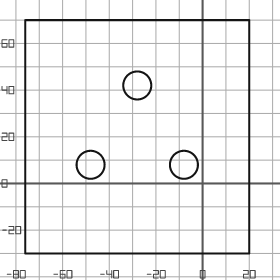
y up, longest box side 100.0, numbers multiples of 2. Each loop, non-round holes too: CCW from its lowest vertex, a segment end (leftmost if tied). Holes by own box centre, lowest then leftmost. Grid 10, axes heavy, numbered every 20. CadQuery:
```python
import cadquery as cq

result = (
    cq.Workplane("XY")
    .moveTo(-76.0, -30.0)
    .lineTo(20.0, -30.0)
    .lineTo(20.0, 70.0)
    .lineTo(-76.0, 70.0)
    .close()
    .moveTo(-48.0, 8.0)
    .circle(6.0)
    .moveTo(-8.0, 8.0)
    .circle(6.0)
    .moveTo(-28.0, 42.0)
    .circle(6.0)
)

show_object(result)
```